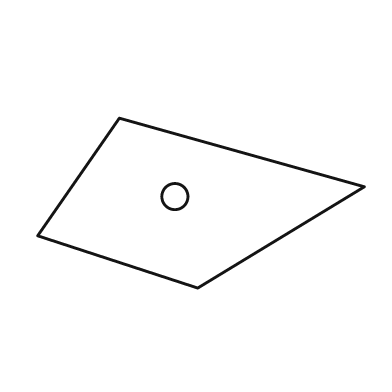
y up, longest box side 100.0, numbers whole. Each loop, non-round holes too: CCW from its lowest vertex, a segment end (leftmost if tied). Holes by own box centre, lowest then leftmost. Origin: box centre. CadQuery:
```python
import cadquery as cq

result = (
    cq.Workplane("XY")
    .moveTo(-1.0, -26.0)
    .lineTo(50.0, 5.0)
    .lineTo(-25.0, 26.0)
    .lineTo(-50.0, -10.0)
    .close()
    .moveTo(-8.0, 2.0)
    .circle(4.0)
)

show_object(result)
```